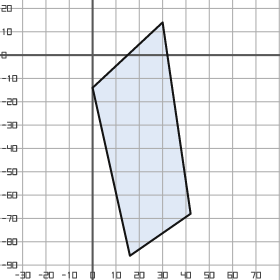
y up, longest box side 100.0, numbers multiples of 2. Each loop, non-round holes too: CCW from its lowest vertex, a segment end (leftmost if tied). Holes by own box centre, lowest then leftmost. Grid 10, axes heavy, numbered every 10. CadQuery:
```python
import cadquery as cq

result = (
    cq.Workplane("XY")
    .moveTo(16.0, -86.0)
    .lineTo(42.0, -68.0)
    .lineTo(30.0, 14.0)
    .lineTo(0.0, -14.0)
    .close()
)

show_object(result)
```